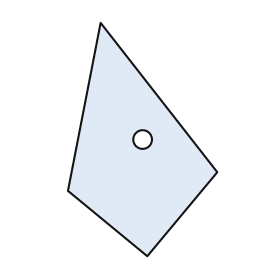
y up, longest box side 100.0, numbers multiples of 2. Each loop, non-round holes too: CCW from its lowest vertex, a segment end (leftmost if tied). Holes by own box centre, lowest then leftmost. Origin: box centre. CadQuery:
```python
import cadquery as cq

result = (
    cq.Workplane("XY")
    .moveTo(2.0, -50.0)
    .lineTo(32.0, -14.0)
    .lineTo(-18.0, 50.0)
    .lineTo(-32.0, -22.0)
    .close()
    .moveTo(0.0, 0.0)
    .circle(4.0)
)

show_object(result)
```